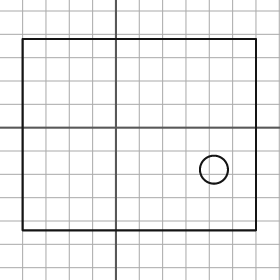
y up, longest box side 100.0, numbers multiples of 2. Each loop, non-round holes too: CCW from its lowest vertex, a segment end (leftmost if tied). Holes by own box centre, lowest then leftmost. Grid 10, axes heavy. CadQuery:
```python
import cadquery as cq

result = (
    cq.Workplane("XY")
    .moveTo(-40.0, -44.0)
    .lineTo(60.0, -44.0)
    .lineTo(60.0, 38.0)
    .lineTo(-40.0, 38.0)
    .close()
    .moveTo(42.0, -18.0)
    .circle(6.0)
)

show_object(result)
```